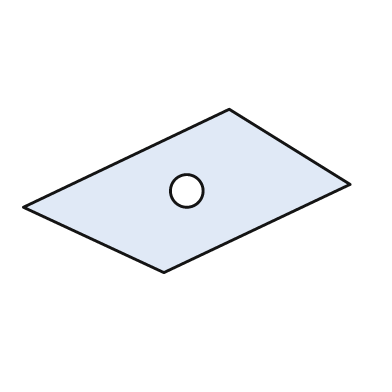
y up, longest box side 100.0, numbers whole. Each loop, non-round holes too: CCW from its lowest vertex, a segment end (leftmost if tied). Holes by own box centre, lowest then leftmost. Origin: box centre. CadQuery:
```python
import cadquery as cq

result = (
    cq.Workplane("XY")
    .moveTo(-7.0, -25.0)
    .lineTo(50.0, 2.0)
    .lineTo(13.0, 25.0)
    .lineTo(-50.0, -5.0)
    .close()
    .moveTo(0.0, 0.0)
    .circle(5.0)
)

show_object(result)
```